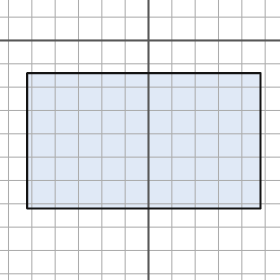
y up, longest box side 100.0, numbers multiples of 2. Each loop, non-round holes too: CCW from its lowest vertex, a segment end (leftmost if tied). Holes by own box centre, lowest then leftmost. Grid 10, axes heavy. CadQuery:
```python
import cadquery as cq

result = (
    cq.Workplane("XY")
    .moveTo(-52.0, -72.0)
    .lineTo(48.0, -72.0)
    .lineTo(48.0, -14.0)
    .lineTo(-52.0, -14.0)
    .close()
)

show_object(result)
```